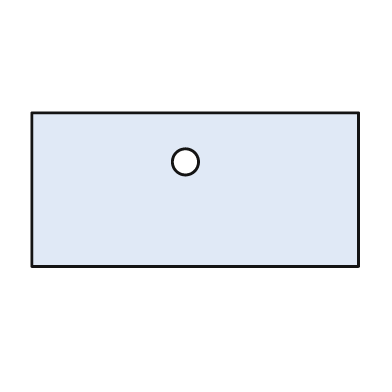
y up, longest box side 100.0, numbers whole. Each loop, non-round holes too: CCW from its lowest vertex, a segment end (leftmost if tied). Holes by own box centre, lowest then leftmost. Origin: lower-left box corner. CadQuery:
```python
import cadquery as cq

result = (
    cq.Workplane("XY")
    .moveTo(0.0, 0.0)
    .lineTo(100.0, 0.0)
    .lineTo(100.0, 47.0)
    .lineTo(0.0, 47.0)
    .close()
    .moveTo(47.0, 32.0)
    .circle(4.0)
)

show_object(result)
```